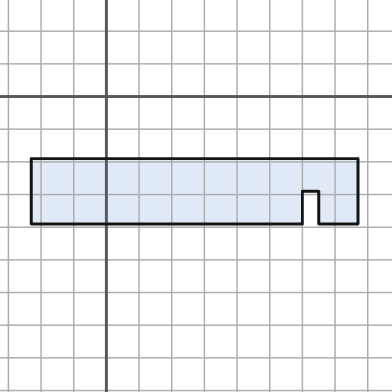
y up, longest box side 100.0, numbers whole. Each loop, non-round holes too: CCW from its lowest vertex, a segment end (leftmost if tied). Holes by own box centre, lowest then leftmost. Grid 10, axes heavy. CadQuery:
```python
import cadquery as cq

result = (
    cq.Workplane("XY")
    .moveTo(-23.0, -39.0)
    .lineTo(60.0, -39.0)
    .lineTo(60.0, -29.0)
    .lineTo(65.0, -29.0)
    .lineTo(65.0, -39.0)
    .lineTo(77.0, -39.0)
    .lineTo(77.0, -19.0)
    .lineTo(-23.0, -19.0)
    .close()
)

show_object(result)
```